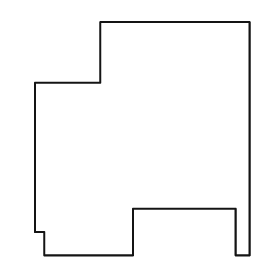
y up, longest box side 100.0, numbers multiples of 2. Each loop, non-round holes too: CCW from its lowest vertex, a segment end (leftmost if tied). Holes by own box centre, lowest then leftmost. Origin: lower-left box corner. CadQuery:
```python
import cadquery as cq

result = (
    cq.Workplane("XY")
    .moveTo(4.0, 0.0)
    .lineTo(42.0, 0.0)
    .lineTo(42.0, 20.0)
    .lineTo(86.0, 20.0)
    .lineTo(86.0, 0.0)
    .lineTo(92.0, 0.0)
    .lineTo(92.0, 100.0)
    .lineTo(28.0, 100.0)
    .lineTo(28.0, 74.0)
    .lineTo(0.0, 74.0)
    .lineTo(0.0, 10.0)
    .lineTo(4.0, 10.0)
    .close()
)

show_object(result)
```